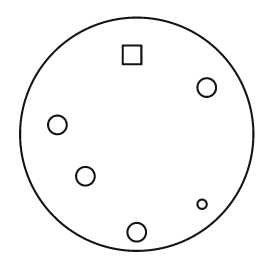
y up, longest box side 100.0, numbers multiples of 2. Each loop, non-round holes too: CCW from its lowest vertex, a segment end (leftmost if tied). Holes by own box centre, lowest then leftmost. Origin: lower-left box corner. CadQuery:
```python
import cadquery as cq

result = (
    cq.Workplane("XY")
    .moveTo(50.0, 50.0)
    .circle(50.0)
    .moveTo(50.0, 8.0)
    .circle(4.0)
    .moveTo(78.0, 20.0)
    .circle(2.0)
    .moveTo(28.0, 32.0)
    .circle(4.0)
    .moveTo(16.0, 54.0)
    .circle(4.0)
    .moveTo(80.0, 70.0)
    .circle(4.0)
    .moveTo(44.0, 80.0)
    .lineTo(52.0, 80.0)
    .lineTo(52.0, 88.0)
    .lineTo(44.0, 88.0)
    .close()
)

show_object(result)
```